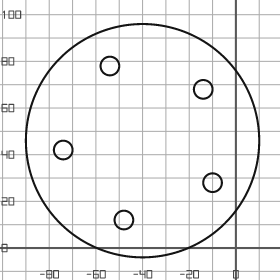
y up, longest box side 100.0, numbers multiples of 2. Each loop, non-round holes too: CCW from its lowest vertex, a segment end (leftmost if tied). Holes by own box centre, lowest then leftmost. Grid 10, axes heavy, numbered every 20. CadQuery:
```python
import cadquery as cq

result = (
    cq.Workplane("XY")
    .moveTo(-40.0, 46.0)
    .circle(50.0)
    .moveTo(-48.0, 12.0)
    .circle(4.0)
    .moveTo(-10.0, 28.0)
    .circle(4.0)
    .moveTo(-74.0, 42.0)
    .circle(4.0)
    .moveTo(-14.0, 68.0)
    .circle(4.0)
    .moveTo(-54.0, 78.0)
    .circle(4.0)
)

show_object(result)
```